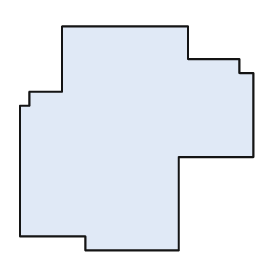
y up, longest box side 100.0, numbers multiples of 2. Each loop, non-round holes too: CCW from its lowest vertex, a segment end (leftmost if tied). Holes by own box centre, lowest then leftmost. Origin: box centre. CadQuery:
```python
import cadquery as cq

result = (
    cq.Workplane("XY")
    .moveTo(-22.0, -48.0)
    .lineTo(18.0, -48.0)
    .lineTo(18.0, -8.0)
    .lineTo(50.0, -8.0)
    .lineTo(50.0, 28.0)
    .lineTo(44.0, 28.0)
    .lineTo(44.0, 34.0)
    .lineTo(22.0, 34.0)
    .lineTo(22.0, 48.0)
    .lineTo(-32.0, 48.0)
    .lineTo(-32.0, 20.0)
    .lineTo(-46.0, 20.0)
    .lineTo(-46.0, 14.0)
    .lineTo(-50.0, 14.0)
    .lineTo(-50.0, -42.0)
    .lineTo(-22.0, -42.0)
    .close()
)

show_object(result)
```